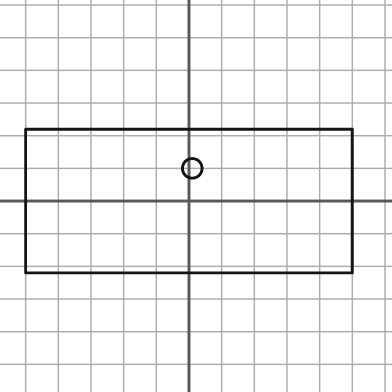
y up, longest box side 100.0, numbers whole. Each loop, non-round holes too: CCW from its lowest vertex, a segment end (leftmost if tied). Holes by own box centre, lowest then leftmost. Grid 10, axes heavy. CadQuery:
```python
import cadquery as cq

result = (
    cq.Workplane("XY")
    .moveTo(-50.0, -22.0)
    .lineTo(50.0, -22.0)
    .lineTo(50.0, 22.0)
    .lineTo(-50.0, 22.0)
    .close()
    .moveTo(1.0, 10.0)
    .circle(3.0)
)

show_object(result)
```